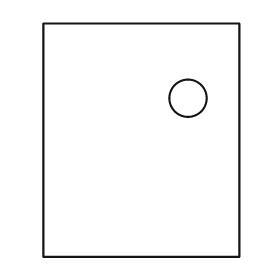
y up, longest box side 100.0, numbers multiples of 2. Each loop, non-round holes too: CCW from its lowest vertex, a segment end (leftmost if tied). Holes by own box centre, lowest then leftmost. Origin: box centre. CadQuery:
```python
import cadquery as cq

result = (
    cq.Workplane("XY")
    .moveTo(-42.0, -50.0)
    .lineTo(42.0, -50.0)
    .lineTo(42.0, 50.0)
    .lineTo(-42.0, 50.0)
    .close()
    .moveTo(20.0, 18.0)
    .circle(8.0)
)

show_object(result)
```